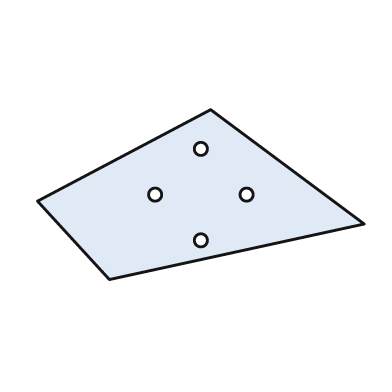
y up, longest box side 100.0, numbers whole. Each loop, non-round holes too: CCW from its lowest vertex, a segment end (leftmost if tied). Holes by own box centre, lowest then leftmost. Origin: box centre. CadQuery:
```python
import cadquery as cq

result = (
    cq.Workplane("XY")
    .moveTo(-28.0, -26.0)
    .lineTo(50.0, -9.0)
    .lineTo(3.0, 26.0)
    .lineTo(-50.0, -2.0)
    .close()
    .moveTo(0.0, -14.0)
    .circle(2.0)
    .moveTo(-14.0, 0.0)
    .circle(2.0)
    .moveTo(14.0, 0.0)
    .circle(2.0)
    .moveTo(0.0, 14.0)
    .circle(2.0)
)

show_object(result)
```